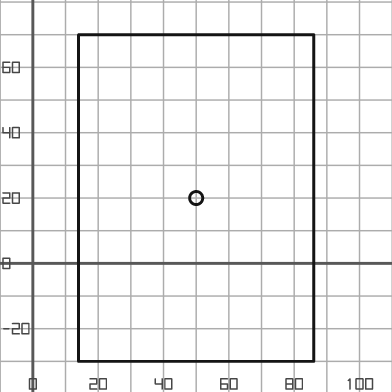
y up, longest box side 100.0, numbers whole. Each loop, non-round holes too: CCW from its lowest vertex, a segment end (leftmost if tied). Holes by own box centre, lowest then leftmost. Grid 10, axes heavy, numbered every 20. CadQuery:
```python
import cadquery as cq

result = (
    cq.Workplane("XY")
    .moveTo(14.0, -30.0)
    .lineTo(86.0, -30.0)
    .lineTo(86.0, 70.0)
    .lineTo(14.0, 70.0)
    .close()
    .moveTo(50.0, 20.0)
    .circle(2.0)
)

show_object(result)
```